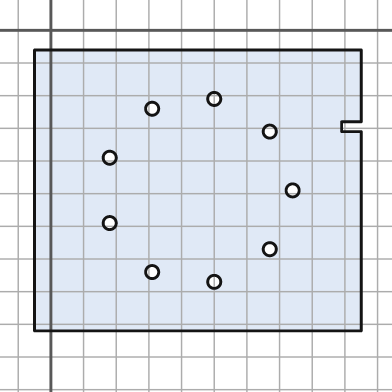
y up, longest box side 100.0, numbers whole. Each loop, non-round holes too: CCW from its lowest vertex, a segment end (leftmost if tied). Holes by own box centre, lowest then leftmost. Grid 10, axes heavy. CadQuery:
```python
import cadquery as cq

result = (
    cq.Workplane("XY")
    .moveTo(-5.0, -92.0)
    .lineTo(95.0, -92.0)
    .lineTo(95.0, -31.0)
    .lineTo(89.0, -31.0)
    .lineTo(89.0, -28.0)
    .lineTo(95.0, -28.0)
    .lineTo(95.0, -6.0)
    .lineTo(-5.0, -6.0)
    .close()
    .moveTo(50.0, -77.0)
    .circle(2.0)
    .moveTo(31.0, -74.0)
    .circle(2.0)
    .moveTo(67.0, -67.0)
    .circle(2.0)
    .moveTo(18.0, -59.0)
    .circle(2.0)
    .moveTo(74.0, -49.0)
    .circle(2.0)
    .moveTo(18.0, -39.0)
    .circle(2.0)
    .moveTo(67.0, -31.0)
    .circle(2.0)
    .moveTo(31.0, -24.0)
    .circle(2.0)
    .moveTo(50.0, -21.0)
    .circle(2.0)
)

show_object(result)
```